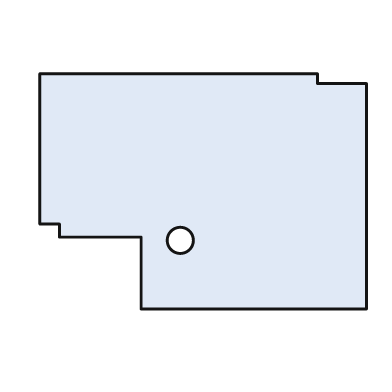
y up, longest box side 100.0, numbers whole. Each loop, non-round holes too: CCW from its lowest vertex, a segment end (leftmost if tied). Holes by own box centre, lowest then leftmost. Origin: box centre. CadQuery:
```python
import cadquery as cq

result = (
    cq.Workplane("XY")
    .moveTo(-19.0, -36.0)
    .lineTo(50.0, -36.0)
    .lineTo(50.0, 33.0)
    .lineTo(35.0, 33.0)
    .lineTo(35.0, 36.0)
    .lineTo(-50.0, 36.0)
    .lineTo(-50.0, -10.0)
    .lineTo(-44.0, -10.0)
    .lineTo(-44.0, -14.0)
    .lineTo(-19.0, -14.0)
    .close()
    .moveTo(-7.0, -15.0)
    .circle(4.0)
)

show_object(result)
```